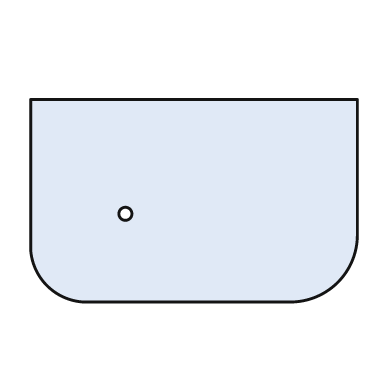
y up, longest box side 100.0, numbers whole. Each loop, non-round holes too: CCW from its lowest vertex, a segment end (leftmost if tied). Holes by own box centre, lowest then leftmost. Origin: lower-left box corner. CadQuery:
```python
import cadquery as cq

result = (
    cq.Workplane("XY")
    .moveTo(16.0, 0.0)
    .lineTo(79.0, 0.0)
    .threePointArc((94.0, 6.0), (100.0, 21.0))
    .lineTo(100.0, 62.0)
    .lineTo(0.0, 62.0)
    .lineTo(0.0, 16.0)
    .threePointArc((5.0, 5.0), (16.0, 0.0))
    .close()
    .moveTo(29.0, 27.0)
    .circle(2.0)
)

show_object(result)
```